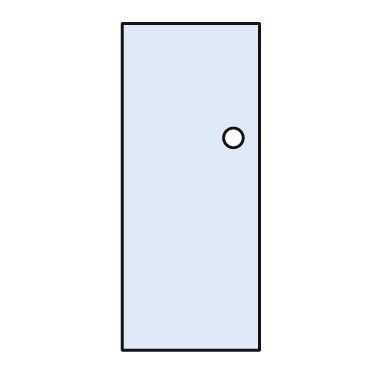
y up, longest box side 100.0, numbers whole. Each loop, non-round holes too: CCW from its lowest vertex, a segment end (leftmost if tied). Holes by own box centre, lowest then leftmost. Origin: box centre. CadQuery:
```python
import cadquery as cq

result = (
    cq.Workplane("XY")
    .moveTo(-21.0, -50.0)
    .lineTo(21.0, -50.0)
    .lineTo(21.0, 50.0)
    .lineTo(-21.0, 50.0)
    .close()
    .moveTo(13.0, 15.0)
    .circle(3.0)
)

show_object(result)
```